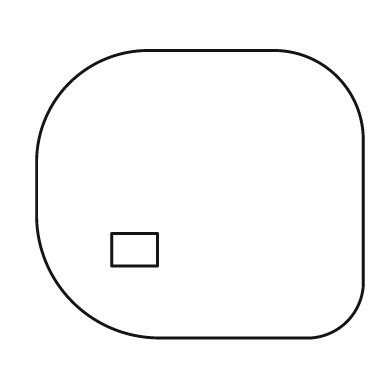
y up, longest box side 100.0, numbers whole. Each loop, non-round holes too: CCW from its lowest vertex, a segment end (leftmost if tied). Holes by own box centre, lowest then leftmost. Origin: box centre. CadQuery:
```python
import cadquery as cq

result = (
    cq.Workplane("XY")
    .moveTo(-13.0, -44.0)
    .lineTo(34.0, -44.0)
    .threePointArc((45.0, -39.0), (50.0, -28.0))
    .lineTo(50.0, 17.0)
    .threePointArc((42.0, 36.0), (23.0, 44.0))
    .lineTo(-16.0, 44.0)
    .threePointArc((-40.0, 34.0), (-50.0, 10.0))
    .lineTo(-50.0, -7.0)
    .threePointArc((-39.0, -33.0), (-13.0, -44.0))
    .close()
    .moveTo(-27.0, -22.0)
    .lineTo(-13.0, -22.0)
    .lineTo(-13.0, -12.0)
    .lineTo(-27.0, -12.0)
    .close()
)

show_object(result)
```